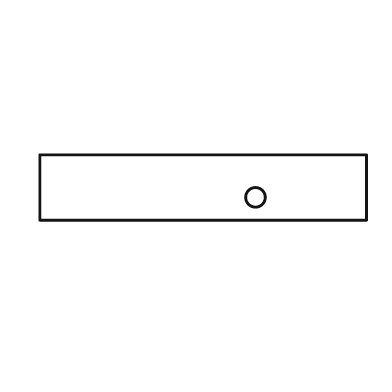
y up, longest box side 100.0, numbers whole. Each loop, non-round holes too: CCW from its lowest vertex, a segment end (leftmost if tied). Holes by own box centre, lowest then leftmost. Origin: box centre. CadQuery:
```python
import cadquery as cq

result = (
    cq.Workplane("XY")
    .moveTo(-50.0, -10.0)
    .lineTo(50.0, -10.0)
    .lineTo(50.0, 10.0)
    .lineTo(-50.0, 10.0)
    .close()
    .moveTo(16.0, -3.0)
    .circle(3.0)
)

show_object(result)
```